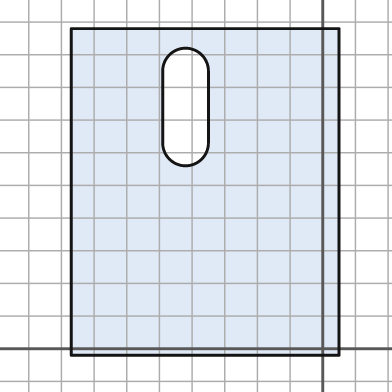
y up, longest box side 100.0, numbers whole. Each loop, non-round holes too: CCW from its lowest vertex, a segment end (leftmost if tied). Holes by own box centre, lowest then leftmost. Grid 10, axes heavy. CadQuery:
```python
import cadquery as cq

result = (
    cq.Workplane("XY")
    .moveTo(-77.0, -2.0)
    .lineTo(5.0, -2.0)
    .lineTo(5.0, 98.0)
    .lineTo(-77.0, 98.0)
    .close()
    .moveTo(-49.0, 63.0)
    .threePointArc((-42.0, 56.0), (-35.0, 63.0))
    .lineTo(-35.0, 85.0)
    .threePointArc((-42.0, 92.0), (-49.0, 85.0))
    .close()
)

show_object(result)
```